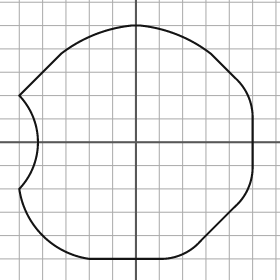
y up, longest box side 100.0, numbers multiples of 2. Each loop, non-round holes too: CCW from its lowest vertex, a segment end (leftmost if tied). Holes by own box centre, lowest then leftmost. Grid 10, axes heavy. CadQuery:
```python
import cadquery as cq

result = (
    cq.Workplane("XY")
    .moveTo(-20.0, -50.0)
    .lineTo(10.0, -50.0)
    .threePointArc((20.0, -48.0), (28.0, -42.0))
    .lineTo(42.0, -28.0)
    .threePointArc((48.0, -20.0), (50.0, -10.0))
    .lineTo(50.0, 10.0)
    .threePointArc((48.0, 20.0), (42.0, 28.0))
    .lineTo(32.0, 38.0)
    .threePointArc((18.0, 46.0), (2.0, 50.0))
    .lineTo(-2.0, 50.0)
    .threePointArc((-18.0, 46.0), (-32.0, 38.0))
    .lineTo(-50.0, 20.0)
    .threePointArc((-42.0, 0.0), (-50.0, -20.0))
    .threePointArc((-40.0, -40.0), (-20.0, -50.0))
    .close()
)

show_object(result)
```